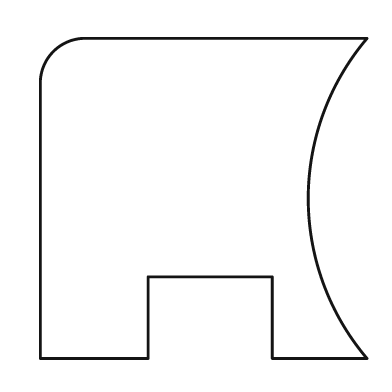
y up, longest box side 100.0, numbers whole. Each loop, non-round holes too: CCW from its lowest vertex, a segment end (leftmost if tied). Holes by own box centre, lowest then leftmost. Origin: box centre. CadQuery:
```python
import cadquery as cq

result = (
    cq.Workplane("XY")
    .moveTo(-50.0, -49.0)
    .lineTo(-17.0, -49.0)
    .lineTo(-17.0, -24.0)
    .lineTo(21.0, -24.0)
    .lineTo(21.0, -49.0)
    .lineTo(50.0, -49.0)
    .threePointArc((32.0, 0.0), (50.0, 49.0))
    .lineTo(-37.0, 49.0)
    .threePointArc((-46.0, 45.0), (-50.0, 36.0))
    .close()
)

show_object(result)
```